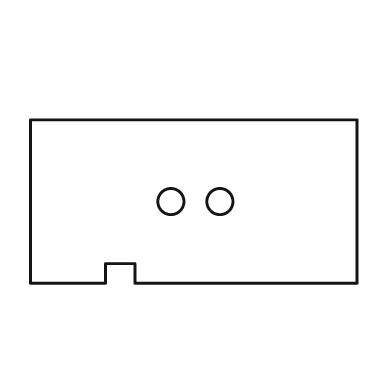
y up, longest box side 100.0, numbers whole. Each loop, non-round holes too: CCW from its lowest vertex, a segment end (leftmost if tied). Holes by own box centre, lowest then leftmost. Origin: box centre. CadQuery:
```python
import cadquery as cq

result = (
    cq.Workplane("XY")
    .moveTo(-50.0, -25.0)
    .lineTo(-27.0, -25.0)
    .lineTo(-27.0, -19.0)
    .lineTo(-18.0, -19.0)
    .lineTo(-18.0, -25.0)
    .lineTo(50.0, -25.0)
    .lineTo(50.0, 25.0)
    .lineTo(-50.0, 25.0)
    .close()
    .moveTo(-7.0, 0.0)
    .circle(4.0)
    .moveTo(8.0, 0.0)
    .circle(4.0)
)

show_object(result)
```